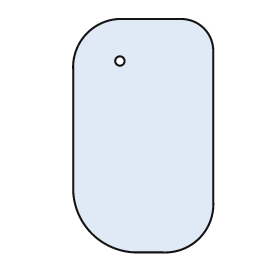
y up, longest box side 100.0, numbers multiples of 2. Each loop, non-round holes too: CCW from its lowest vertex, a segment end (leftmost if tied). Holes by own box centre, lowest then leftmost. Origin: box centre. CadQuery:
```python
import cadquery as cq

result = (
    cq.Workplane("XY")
    .moveTo(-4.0, -50.0)
    .lineTo(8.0, -50.0)
    .threePointArc((24.0, -44.0), (30.0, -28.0))
    .lineTo(30.0, 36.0)
    .threePointArc((26.0, 46.0), (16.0, 50.0))
    .lineTo(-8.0, 50.0)
    .threePointArc((-24.0, 44.0), (-30.0, 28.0))
    .lineTo(-30.0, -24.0)
    .threePointArc((-22.0, -42.0), (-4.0, -50.0))
    .close()
    .moveTo(-10.0, 32.0)
    .circle(2.0)
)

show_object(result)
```